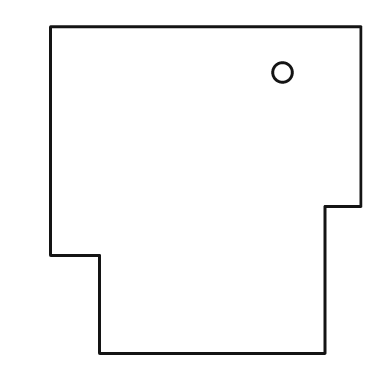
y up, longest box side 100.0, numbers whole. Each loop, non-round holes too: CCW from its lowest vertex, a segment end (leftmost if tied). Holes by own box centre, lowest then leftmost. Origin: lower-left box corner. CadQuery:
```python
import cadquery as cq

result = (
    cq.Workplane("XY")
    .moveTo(15.0, 0.0)
    .lineTo(84.0, 0.0)
    .lineTo(84.0, 45.0)
    .lineTo(95.0, 45.0)
    .lineTo(95.0, 100.0)
    .lineTo(0.0, 100.0)
    .lineTo(0.0, 30.0)
    .lineTo(15.0, 30.0)
    .close()
    .moveTo(71.0, 86.0)
    .circle(3.0)
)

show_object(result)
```